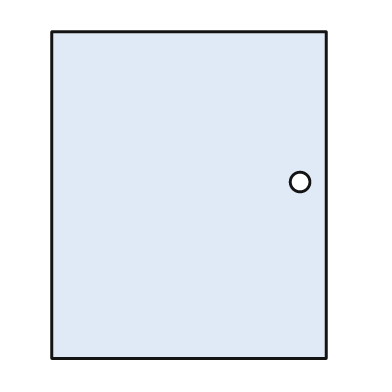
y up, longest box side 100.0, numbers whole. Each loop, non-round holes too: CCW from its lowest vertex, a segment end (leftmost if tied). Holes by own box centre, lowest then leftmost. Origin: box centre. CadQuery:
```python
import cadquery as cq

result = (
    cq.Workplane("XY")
    .moveTo(-42.0, -50.0)
    .lineTo(42.0, -50.0)
    .lineTo(42.0, 50.0)
    .lineTo(-42.0, 50.0)
    .close()
    .moveTo(34.0, 4.0)
    .circle(3.0)
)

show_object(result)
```